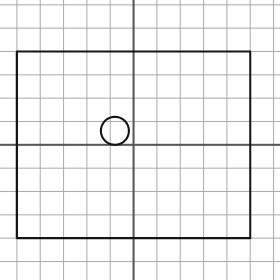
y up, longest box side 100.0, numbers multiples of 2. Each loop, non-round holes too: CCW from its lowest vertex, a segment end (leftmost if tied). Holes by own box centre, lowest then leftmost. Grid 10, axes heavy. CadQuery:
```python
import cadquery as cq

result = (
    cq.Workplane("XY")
    .moveTo(-50.0, -40.0)
    .lineTo(50.0, -40.0)
    .lineTo(50.0, 40.0)
    .lineTo(-50.0, 40.0)
    .close()
    .moveTo(-8.0, 6.0)
    .circle(6.0)
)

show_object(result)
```